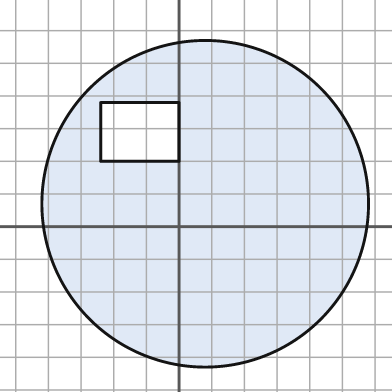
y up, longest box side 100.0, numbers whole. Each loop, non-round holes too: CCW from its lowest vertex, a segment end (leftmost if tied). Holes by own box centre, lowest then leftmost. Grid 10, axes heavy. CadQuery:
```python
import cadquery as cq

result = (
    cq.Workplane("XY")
    .moveTo(8.0, 7.0)
    .circle(50.0)
    .moveTo(-24.0, 20.0)
    .lineTo(0.0, 20.0)
    .lineTo(0.0, 38.0)
    .lineTo(-24.0, 38.0)
    .close()
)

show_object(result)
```